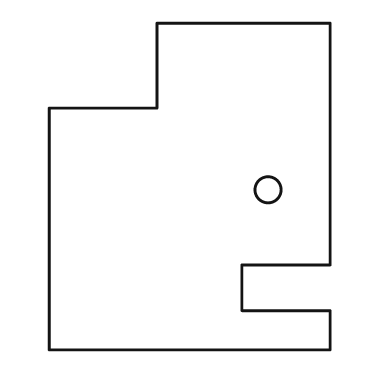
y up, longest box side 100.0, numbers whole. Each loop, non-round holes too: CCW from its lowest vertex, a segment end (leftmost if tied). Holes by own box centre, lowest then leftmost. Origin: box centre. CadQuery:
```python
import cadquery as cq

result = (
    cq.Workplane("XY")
    .moveTo(-43.0, -50.0)
    .lineTo(43.0, -50.0)
    .lineTo(43.0, -38.0)
    .lineTo(16.0, -38.0)
    .lineTo(16.0, -24.0)
    .lineTo(43.0, -24.0)
    .lineTo(43.0, 50.0)
    .lineTo(-10.0, 50.0)
    .lineTo(-10.0, 24.0)
    .lineTo(-43.0, 24.0)
    .close()
    .moveTo(24.0, -1.0)
    .circle(4.0)
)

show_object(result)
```